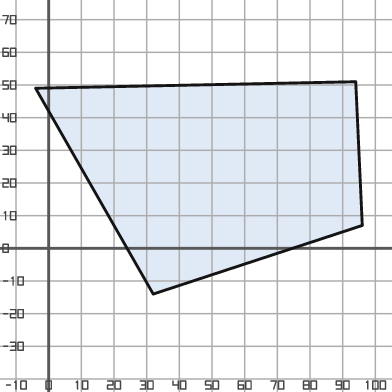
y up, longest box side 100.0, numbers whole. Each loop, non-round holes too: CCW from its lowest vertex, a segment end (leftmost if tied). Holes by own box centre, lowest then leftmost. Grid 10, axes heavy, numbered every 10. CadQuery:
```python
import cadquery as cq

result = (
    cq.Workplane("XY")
    .moveTo(32.0, -14.0)
    .lineTo(96.0, 7.0)
    .lineTo(94.0, 51.0)
    .lineTo(-4.0, 49.0)
    .close()
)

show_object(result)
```